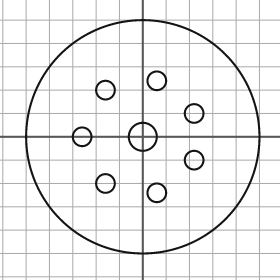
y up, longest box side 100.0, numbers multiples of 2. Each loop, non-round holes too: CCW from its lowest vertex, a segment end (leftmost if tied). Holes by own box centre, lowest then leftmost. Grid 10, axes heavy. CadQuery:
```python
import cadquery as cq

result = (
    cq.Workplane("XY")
    .moveTo(0.0, 0.0)
    .circle(50.0)
    .moveTo(6.0, -24.0)
    .circle(4.0)
    .moveTo(-16.0, -20.0)
    .circle(4.0)
    .moveTo(22.0, -10.0)
    .circle(4.0)
    .moveTo(-26.0, 0.0)
    .circle(4.0)
    .moveTo(0.0, 0.0)
    .circle(6.0)
    .moveTo(22.0, 10.0)
    .circle(4.0)
    .moveTo(-16.0, 20.0)
    .circle(4.0)
    .moveTo(6.0, 24.0)
    .circle(4.0)
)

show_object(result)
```